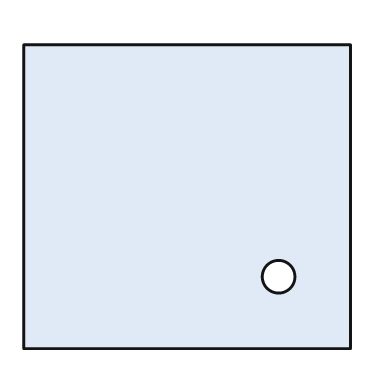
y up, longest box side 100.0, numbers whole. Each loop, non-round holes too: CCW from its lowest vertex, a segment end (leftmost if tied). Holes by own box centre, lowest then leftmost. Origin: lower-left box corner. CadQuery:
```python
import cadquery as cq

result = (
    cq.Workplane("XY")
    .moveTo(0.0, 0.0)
    .lineTo(100.0, 0.0)
    .lineTo(100.0, 93.0)
    .lineTo(0.0, 93.0)
    .close()
    .moveTo(78.0, 22.0)
    .circle(5.0)
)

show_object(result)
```